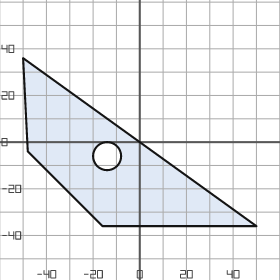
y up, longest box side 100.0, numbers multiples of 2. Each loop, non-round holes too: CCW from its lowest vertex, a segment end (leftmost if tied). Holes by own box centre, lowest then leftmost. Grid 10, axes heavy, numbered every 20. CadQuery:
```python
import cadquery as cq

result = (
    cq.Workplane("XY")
    .moveTo(-16.0, -36.0)
    .lineTo(50.0, -36.0)
    .lineTo(-50.0, 36.0)
    .lineTo(-48.0, -4.0)
    .close()
    .moveTo(-14.0, -6.0)
    .circle(6.0)
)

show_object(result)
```